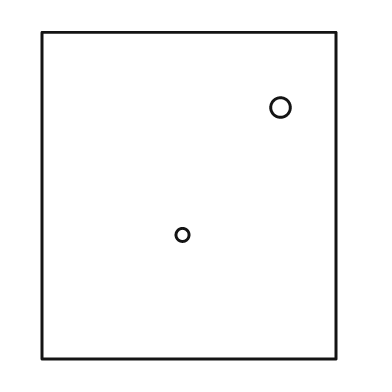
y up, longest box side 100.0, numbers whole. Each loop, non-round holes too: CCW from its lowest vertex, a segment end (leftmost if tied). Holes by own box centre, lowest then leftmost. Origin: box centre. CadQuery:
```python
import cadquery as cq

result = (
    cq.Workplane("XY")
    .moveTo(-45.0, -50.0)
    .lineTo(45.0, -50.0)
    .lineTo(45.0, 50.0)
    .lineTo(-45.0, 50.0)
    .close()
    .moveTo(-2.0, -12.0)
    .circle(2.0)
    .moveTo(28.0, 27.0)
    .circle(3.0)
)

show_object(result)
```